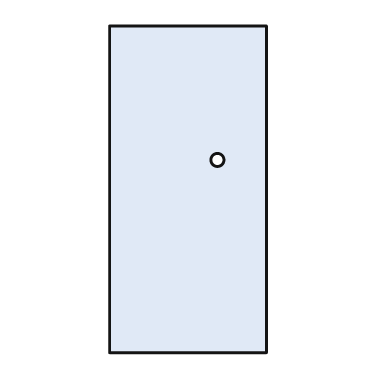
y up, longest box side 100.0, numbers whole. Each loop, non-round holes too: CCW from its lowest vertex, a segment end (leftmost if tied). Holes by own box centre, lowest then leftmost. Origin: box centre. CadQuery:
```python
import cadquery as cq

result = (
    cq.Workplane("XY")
    .moveTo(-24.0, -50.0)
    .lineTo(24.0, -50.0)
    .lineTo(24.0, 50.0)
    .lineTo(-24.0, 50.0)
    .close()
    .moveTo(9.0, 9.0)
    .circle(2.0)
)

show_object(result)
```